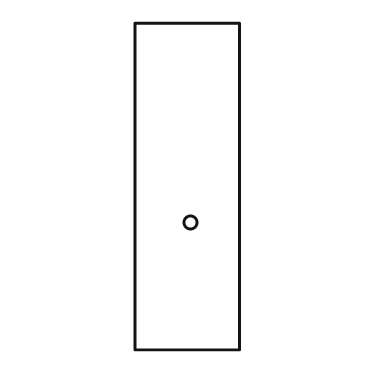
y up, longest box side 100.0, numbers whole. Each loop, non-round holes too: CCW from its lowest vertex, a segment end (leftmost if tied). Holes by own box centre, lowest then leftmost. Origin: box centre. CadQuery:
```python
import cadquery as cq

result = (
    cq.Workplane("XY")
    .moveTo(-16.0, -50.0)
    .lineTo(16.0, -50.0)
    .lineTo(16.0, 50.0)
    .lineTo(-16.0, 50.0)
    .close()
    .moveTo(1.0, -11.0)
    .circle(2.0)
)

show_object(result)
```